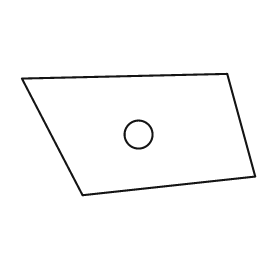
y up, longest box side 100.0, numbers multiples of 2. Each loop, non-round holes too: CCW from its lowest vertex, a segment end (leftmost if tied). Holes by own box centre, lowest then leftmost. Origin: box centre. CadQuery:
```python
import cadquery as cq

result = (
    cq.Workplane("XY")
    .moveTo(-24.0, -26.0)
    .lineTo(50.0, -18.0)
    .lineTo(38.0, 26.0)
    .lineTo(-50.0, 24.0)
    .close()
    .moveTo(0.0, 0.0)
    .circle(6.0)
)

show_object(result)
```